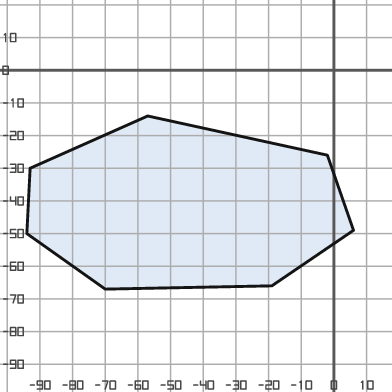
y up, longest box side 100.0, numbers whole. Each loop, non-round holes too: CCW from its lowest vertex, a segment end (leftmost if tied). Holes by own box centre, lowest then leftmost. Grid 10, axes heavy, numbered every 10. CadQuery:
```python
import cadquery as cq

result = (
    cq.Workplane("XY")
    .moveTo(-70.0, -67.0)
    .lineTo(-19.0, -66.0)
    .lineTo(6.0, -49.0)
    .lineTo(-2.0, -26.0)
    .lineTo(-57.0, -14.0)
    .lineTo(-93.0, -30.0)
    .lineTo(-94.0, -50.0)
    .close()
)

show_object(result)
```